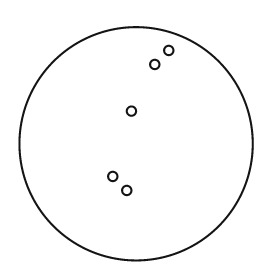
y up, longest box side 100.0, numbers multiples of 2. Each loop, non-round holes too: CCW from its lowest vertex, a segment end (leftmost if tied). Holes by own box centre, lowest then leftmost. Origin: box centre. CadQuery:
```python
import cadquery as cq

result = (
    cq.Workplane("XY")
    .moveTo(0.0, 0.0)
    .circle(50.0)
    .moveTo(-4.0, -20.0)
    .circle(2.0)
    .moveTo(-10.0, -14.0)
    .circle(2.0)
    .moveTo(-2.0, 14.0)
    .circle(2.0)
    .moveTo(8.0, 34.0)
    .circle(2.0)
    .moveTo(14.0, 40.0)
    .circle(2.0)
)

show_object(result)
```